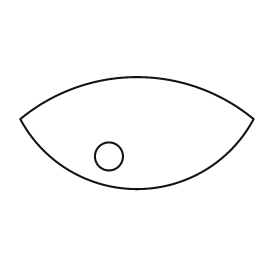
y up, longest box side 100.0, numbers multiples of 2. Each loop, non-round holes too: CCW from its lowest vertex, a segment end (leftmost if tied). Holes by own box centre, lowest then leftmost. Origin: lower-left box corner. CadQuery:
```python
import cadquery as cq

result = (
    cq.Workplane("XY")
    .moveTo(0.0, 30.0)
    .threePointArc((50.0, 0.0), (100.0, 30.0))
    .threePointArc((50.0, 48.0), (0.0, 30.0))
    .close()
    .moveTo(38.0, 14.0)
    .circle(6.0)
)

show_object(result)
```